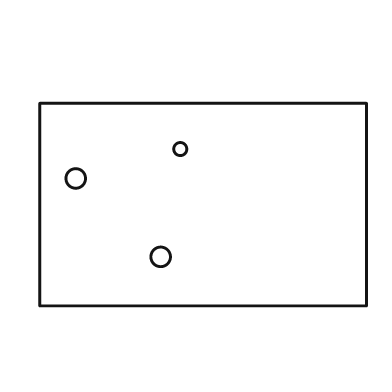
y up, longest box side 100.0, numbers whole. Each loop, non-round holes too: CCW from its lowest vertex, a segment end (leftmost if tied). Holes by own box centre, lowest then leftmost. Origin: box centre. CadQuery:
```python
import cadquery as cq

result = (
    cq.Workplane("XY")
    .moveTo(-50.0, -31.0)
    .lineTo(50.0, -31.0)
    .lineTo(50.0, 31.0)
    .lineTo(-50.0, 31.0)
    .close()
    .moveTo(-13.0, -16.0)
    .circle(3.0)
    .moveTo(-39.0, 8.0)
    .circle(3.0)
    .moveTo(-7.0, 17.0)
    .circle(2.0)
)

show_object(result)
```